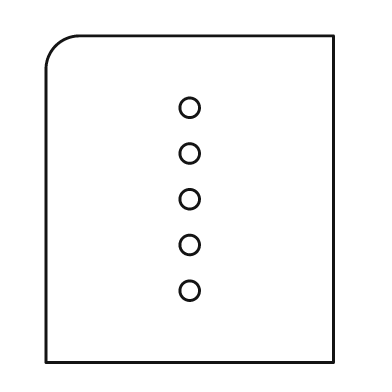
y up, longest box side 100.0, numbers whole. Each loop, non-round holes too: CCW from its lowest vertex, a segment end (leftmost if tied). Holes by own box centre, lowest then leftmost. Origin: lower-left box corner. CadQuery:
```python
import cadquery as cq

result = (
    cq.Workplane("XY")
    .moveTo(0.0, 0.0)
    .lineTo(88.0, 0.0)
    .lineTo(88.0, 100.0)
    .lineTo(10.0, 100.0)
    .threePointArc((3.0, 97.0), (0.0, 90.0))
    .close()
    .moveTo(44.0, 22.0)
    .circle(3.0)
    .moveTo(44.0, 36.0)
    .circle(3.0)
    .moveTo(44.0, 50.0)
    .circle(3.0)
    .moveTo(44.0, 64.0)
    .circle(3.0)
    .moveTo(44.0, 78.0)
    .circle(3.0)
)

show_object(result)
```